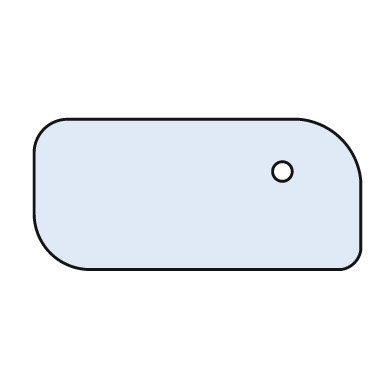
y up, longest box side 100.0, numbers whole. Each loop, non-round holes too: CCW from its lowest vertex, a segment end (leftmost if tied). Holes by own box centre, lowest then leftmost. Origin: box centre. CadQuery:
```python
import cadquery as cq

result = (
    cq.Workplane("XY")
    .moveTo(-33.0, -23.0)
    .lineTo(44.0, -23.0)
    .threePointArc((48.0, -21.0), (50.0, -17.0))
    .lineTo(50.0, 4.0)
    .threePointArc((44.0, 17.0), (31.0, 23.0))
    .lineTo(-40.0, 23.0)
    .threePointArc((-47.0, 20.0), (-50.0, 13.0))
    .lineTo(-50.0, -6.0)
    .threePointArc((-45.0, -18.0), (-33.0, -23.0))
    .close()
    .moveTo(26.0, 7.0)
    .circle(3.0)
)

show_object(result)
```